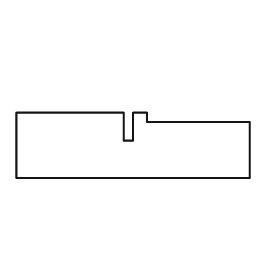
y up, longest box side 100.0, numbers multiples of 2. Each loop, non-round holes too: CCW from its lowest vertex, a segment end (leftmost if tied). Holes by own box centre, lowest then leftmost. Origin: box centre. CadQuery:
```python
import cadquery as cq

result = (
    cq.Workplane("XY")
    .moveTo(-50.0, -14.0)
    .lineTo(50.0, -14.0)
    .lineTo(50.0, 10.0)
    .lineTo(6.0, 10.0)
    .lineTo(6.0, 14.0)
    .lineTo(0.0, 14.0)
    .lineTo(0.0, 2.0)
    .lineTo(-4.0, 2.0)
    .lineTo(-4.0, 14.0)
    .lineTo(-50.0, 14.0)
    .close()
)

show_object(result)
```